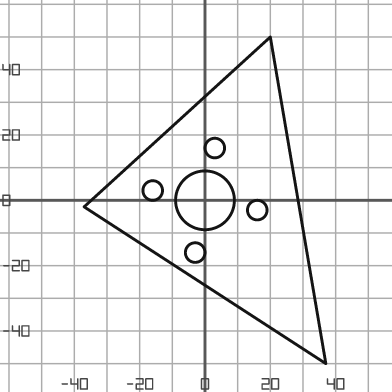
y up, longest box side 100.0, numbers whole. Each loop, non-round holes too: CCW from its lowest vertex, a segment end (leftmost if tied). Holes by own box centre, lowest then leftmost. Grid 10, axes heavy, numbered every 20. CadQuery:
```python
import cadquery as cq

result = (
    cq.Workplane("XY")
    .moveTo(37.0, -50.0)
    .lineTo(20.0, 50.0)
    .lineTo(-37.0, -2.0)
    .close()
    .moveTo(-3.0, -16.0)
    .circle(3.0)
    .moveTo(16.0, -3.0)
    .circle(3.0)
    .moveTo(0.0, 0.0)
    .circle(9.0)
    .moveTo(-16.0, 3.0)
    .circle(3.0)
    .moveTo(3.0, 16.0)
    .circle(3.0)
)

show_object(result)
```